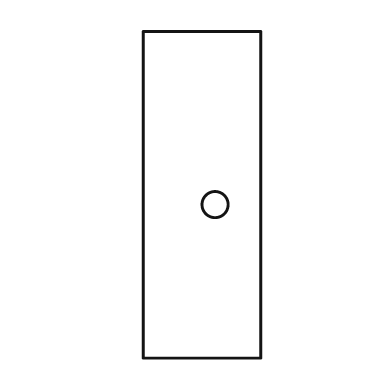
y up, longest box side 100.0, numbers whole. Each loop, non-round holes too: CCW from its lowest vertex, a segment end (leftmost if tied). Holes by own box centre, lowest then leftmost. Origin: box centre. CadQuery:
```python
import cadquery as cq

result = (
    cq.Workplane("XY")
    .moveTo(-18.0, -50.0)
    .lineTo(18.0, -50.0)
    .lineTo(18.0, 50.0)
    .lineTo(-18.0, 50.0)
    .close()
    .moveTo(4.0, -3.0)
    .circle(4.0)
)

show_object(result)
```